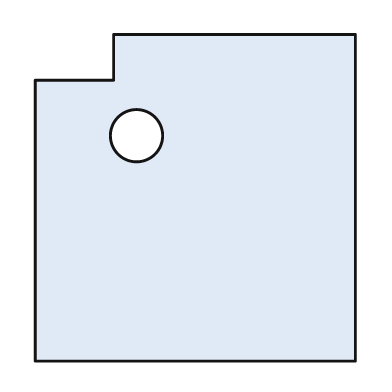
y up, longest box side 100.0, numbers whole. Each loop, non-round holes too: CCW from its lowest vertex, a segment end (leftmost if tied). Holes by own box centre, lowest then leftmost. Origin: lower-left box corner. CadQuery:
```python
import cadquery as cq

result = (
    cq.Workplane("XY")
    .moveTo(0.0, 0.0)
    .lineTo(98.0, 0.0)
    .lineTo(98.0, 100.0)
    .lineTo(24.0, 100.0)
    .lineTo(24.0, 86.0)
    .lineTo(0.0, 86.0)
    .close()
    .moveTo(31.0, 69.0)
    .circle(8.0)
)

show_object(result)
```